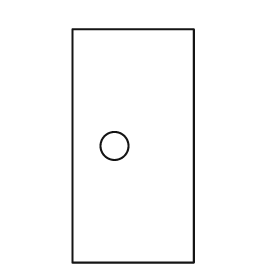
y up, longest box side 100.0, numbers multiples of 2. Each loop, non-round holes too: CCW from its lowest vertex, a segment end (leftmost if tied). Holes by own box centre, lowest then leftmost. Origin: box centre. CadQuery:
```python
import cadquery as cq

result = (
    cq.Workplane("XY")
    .moveTo(-26.0, -50.0)
    .lineTo(26.0, -50.0)
    .lineTo(26.0, 50.0)
    .lineTo(-26.0, 50.0)
    .close()
    .moveTo(-8.0, 0.0)
    .circle(6.0)
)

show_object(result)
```